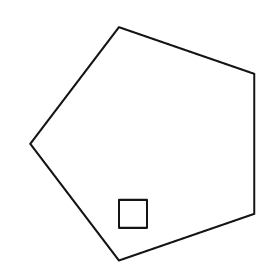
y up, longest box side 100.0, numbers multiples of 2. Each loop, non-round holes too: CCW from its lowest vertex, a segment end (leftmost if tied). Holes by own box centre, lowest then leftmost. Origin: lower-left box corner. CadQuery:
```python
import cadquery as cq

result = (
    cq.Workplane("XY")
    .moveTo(38.0, 0.0)
    .lineTo(96.0, 20.0)
    .lineTo(96.0, 80.0)
    .lineTo(38.0, 100.0)
    .lineTo(0.0, 50.0)
    .close()
    .moveTo(38.0, 14.0)
    .lineTo(50.0, 14.0)
    .lineTo(50.0, 26.0)
    .lineTo(38.0, 26.0)
    .close()
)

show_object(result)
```